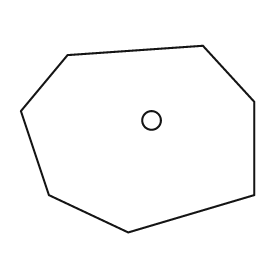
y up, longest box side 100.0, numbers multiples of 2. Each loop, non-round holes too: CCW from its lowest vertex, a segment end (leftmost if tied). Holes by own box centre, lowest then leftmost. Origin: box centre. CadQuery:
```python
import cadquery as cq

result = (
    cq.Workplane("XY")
    .moveTo(-4.0, -40.0)
    .lineTo(50.0, -24.0)
    .lineTo(50.0, 16.0)
    .lineTo(28.0, 40.0)
    .lineTo(-30.0, 36.0)
    .lineTo(-50.0, 12.0)
    .lineTo(-38.0, -24.0)
    .close()
    .moveTo(6.0, 8.0)
    .circle(4.0)
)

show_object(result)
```